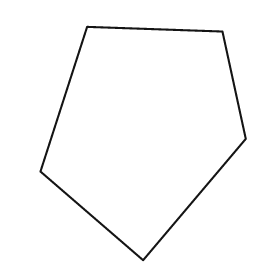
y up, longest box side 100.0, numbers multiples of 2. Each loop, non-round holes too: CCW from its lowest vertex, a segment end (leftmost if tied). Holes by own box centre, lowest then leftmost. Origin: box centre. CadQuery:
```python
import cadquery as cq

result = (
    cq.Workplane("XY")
    .moveTo(0.0, -50.0)
    .lineTo(44.0, 2.0)
    .lineTo(34.0, 48.0)
    .lineTo(-24.0, 50.0)
    .lineTo(-44.0, -12.0)
    .close()
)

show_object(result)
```